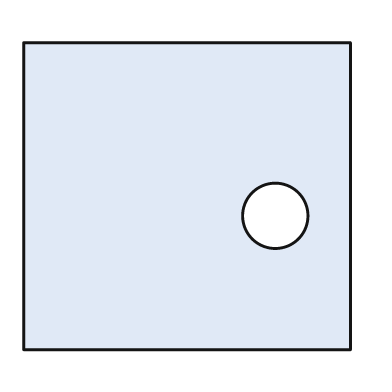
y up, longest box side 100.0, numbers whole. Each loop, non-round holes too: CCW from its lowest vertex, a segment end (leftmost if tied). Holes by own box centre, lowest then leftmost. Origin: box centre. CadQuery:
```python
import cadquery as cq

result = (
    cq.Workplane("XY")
    .moveTo(-50.0, -47.0)
    .lineTo(50.0, -47.0)
    .lineTo(50.0, 47.0)
    .lineTo(-50.0, 47.0)
    .close()
    .moveTo(27.0, -6.0)
    .circle(10.0)
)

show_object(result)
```